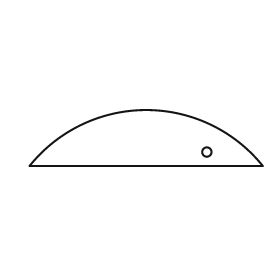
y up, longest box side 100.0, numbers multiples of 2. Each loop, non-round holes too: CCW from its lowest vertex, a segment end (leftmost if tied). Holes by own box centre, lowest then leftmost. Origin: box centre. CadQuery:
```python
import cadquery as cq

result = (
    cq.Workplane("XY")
    .moveTo(-50.0, -12.0)
    .lineTo(50.0, -12.0)
    .threePointArc((0.0, 12.0), (-50.0, -12.0))
    .close()
    .moveTo(26.0, -6.0)
    .circle(2.0)
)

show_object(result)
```